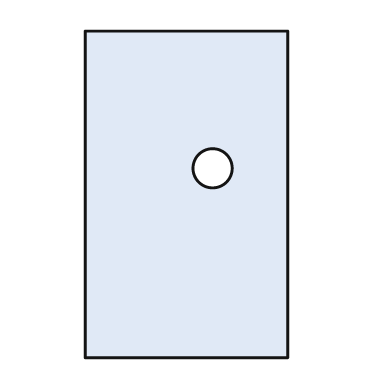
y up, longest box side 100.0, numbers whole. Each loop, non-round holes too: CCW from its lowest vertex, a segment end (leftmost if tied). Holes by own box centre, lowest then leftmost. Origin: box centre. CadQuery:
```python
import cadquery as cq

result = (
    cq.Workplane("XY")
    .moveTo(-31.0, -50.0)
    .lineTo(31.0, -50.0)
    .lineTo(31.0, 50.0)
    .lineTo(-31.0, 50.0)
    .close()
    .moveTo(8.0, 8.0)
    .circle(6.0)
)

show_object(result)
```